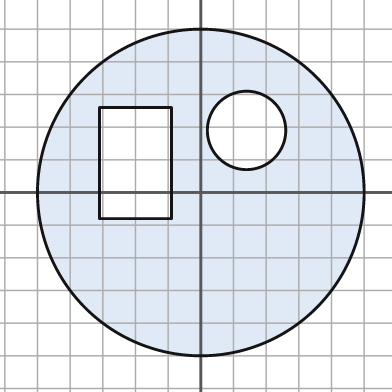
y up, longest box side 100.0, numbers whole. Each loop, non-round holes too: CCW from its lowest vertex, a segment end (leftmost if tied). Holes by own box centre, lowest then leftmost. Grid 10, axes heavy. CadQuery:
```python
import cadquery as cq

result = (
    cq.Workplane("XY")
    .moveTo(0.0, 0.0)
    .circle(50.0)
    .moveTo(-31.0, -8.0)
    .lineTo(-9.0, -8.0)
    .lineTo(-9.0, 26.0)
    .lineTo(-31.0, 26.0)
    .close()
    .moveTo(14.0, 19.0)
    .circle(12.0)
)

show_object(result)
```